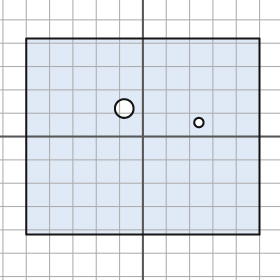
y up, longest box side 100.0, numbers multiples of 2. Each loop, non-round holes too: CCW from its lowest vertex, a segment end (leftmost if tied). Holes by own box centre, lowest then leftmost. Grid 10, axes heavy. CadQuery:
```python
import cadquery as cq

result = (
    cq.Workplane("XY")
    .moveTo(-50.0, -42.0)
    .lineTo(50.0, -42.0)
    .lineTo(50.0, 42.0)
    .lineTo(-50.0, 42.0)
    .close()
    .moveTo(24.0, 6.0)
    .circle(2.0)
    .moveTo(-8.0, 12.0)
    .circle(4.0)
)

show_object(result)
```